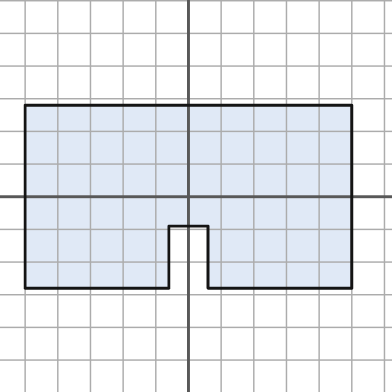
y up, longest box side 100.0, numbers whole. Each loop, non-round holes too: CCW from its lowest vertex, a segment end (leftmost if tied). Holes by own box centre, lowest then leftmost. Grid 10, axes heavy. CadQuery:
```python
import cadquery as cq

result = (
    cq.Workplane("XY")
    .moveTo(-50.0, -28.0)
    .lineTo(-6.0, -28.0)
    .lineTo(-6.0, -9.0)
    .lineTo(6.0, -9.0)
    .lineTo(6.0, -28.0)
    .lineTo(50.0, -28.0)
    .lineTo(50.0, 28.0)
    .lineTo(-50.0, 28.0)
    .close()
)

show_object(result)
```